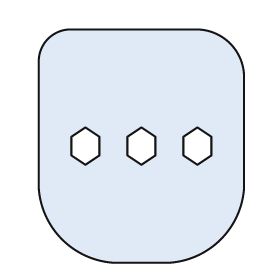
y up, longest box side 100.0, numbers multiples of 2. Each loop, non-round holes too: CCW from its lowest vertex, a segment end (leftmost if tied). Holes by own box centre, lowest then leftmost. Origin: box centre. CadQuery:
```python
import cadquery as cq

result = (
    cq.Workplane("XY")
    .moveTo(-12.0, -50.0)
    .lineTo(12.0, -50.0)
    .threePointArc((34.0, -40.0), (44.0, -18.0))
    .lineTo(44.0, 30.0)
    .threePointArc((38.0, 44.0), (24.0, 50.0))
    .lineTo(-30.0, 50.0)
    .threePointArc((-40.0, 46.0), (-44.0, 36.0))
    .lineTo(-44.0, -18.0)
    .threePointArc((-34.0, -40.0), (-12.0, -50.0))
    .close()
    .moveTo(-24.0, -8.0)
    .lineTo(-18.0, -4.0)
    .lineTo(-18.0, 4.0)
    .lineTo(-24.0, 8.0)
    .lineTo(-30.0, 4.0)
    .lineTo(-30.0, -4.0)
    .close()
    .moveTo(0.0, -8.0)
    .lineTo(6.0, -4.0)
    .lineTo(6.0, 4.0)
    .lineTo(0.0, 8.0)
    .lineTo(-6.0, 4.0)
    .lineTo(-6.0, -4.0)
    .close()
    .moveTo(24.0, -8.0)
    .lineTo(30.0, -4.0)
    .lineTo(30.0, 4.0)
    .lineTo(24.0, 8.0)
    .lineTo(18.0, 4.0)
    .lineTo(18.0, -4.0)
    .close()
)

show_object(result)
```